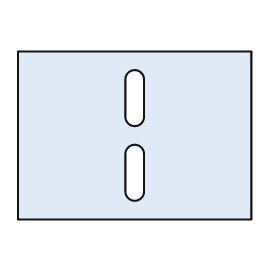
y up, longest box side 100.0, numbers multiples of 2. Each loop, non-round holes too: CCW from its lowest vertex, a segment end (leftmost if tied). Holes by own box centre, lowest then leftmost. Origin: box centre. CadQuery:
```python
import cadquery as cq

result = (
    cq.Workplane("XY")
    .moveTo(-50.0, -36.0)
    .lineTo(50.0, -36.0)
    .lineTo(50.0, 36.0)
    .lineTo(-50.0, 36.0)
    .close()
    .moveTo(-4.0, -24.0)
    .threePointArc((0.0, -28.0), (4.0, -24.0))
    .lineTo(4.0, -8.0)
    .threePointArc((0.0, -4.0), (-4.0, -8.0))
    .close()
    .moveTo(-4.0, 8.0)
    .threePointArc((0.0, 4.0), (4.0, 8.0))
    .lineTo(4.0, 24.0)
    .threePointArc((0.0, 28.0), (-4.0, 24.0))
    .close()
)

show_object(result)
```